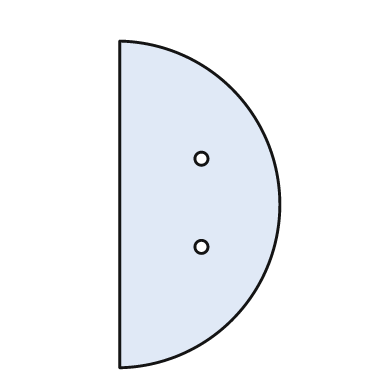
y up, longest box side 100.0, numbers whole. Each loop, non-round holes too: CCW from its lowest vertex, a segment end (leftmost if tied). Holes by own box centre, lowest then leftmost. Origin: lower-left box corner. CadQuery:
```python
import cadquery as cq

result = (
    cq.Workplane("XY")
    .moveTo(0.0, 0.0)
    .threePointArc((49.0, 50.0), (0.0, 100.0))
    .close()
    .moveTo(25.0, 37.0)
    .circle(2.0)
    .moveTo(25.0, 64.0)
    .circle(2.0)
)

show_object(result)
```